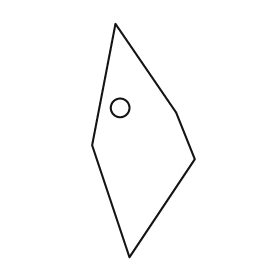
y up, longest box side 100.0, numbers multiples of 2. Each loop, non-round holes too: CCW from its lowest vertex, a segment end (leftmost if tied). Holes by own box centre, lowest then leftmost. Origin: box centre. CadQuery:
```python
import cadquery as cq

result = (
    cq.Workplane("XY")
    .moveTo(-6.0, -50.0)
    .lineTo(22.0, -8.0)
    .lineTo(14.0, 12.0)
    .lineTo(-12.0, 50.0)
    .lineTo(-22.0, -2.0)
    .close()
    .moveTo(-10.0, 14.0)
    .circle(4.0)
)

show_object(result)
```